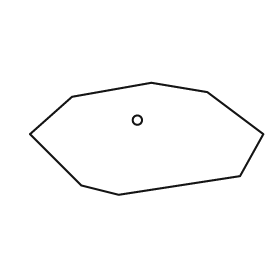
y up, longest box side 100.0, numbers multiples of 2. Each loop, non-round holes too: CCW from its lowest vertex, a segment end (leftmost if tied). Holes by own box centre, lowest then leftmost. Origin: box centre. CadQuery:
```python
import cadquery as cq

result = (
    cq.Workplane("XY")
    .moveTo(-12.0, -24.0)
    .lineTo(40.0, -16.0)
    .lineTo(50.0, 2.0)
    .lineTo(26.0, 20.0)
    .lineTo(2.0, 24.0)
    .lineTo(-32.0, 18.0)
    .lineTo(-50.0, 2.0)
    .lineTo(-28.0, -20.0)
    .close()
    .moveTo(-4.0, 8.0)
    .circle(2.0)
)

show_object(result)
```